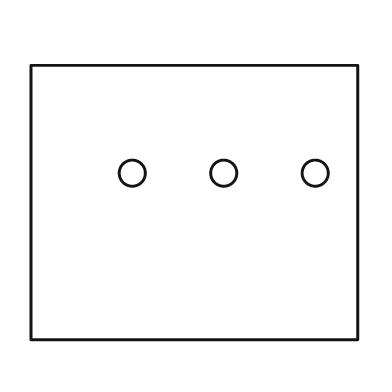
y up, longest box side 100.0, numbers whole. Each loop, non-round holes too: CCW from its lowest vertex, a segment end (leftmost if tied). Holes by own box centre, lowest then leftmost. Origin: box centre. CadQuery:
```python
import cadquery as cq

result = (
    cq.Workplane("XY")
    .moveTo(-50.0, -42.0)
    .lineTo(50.0, -42.0)
    .lineTo(50.0, 42.0)
    .lineTo(-50.0, 42.0)
    .close()
    .moveTo(-19.0, 9.0)
    .circle(4.0)
    .moveTo(9.0, 9.0)
    .circle(4.0)
    .moveTo(37.0, 9.0)
    .circle(4.0)
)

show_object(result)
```